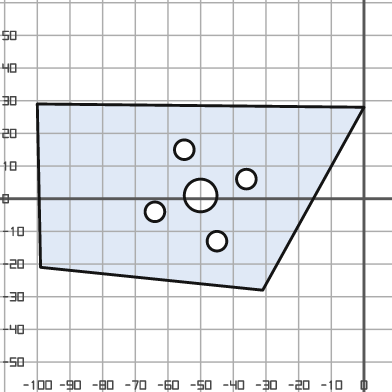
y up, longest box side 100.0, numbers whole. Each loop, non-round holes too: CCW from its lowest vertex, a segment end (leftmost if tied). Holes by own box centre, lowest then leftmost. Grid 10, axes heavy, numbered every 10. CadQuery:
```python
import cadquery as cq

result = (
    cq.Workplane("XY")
    .moveTo(-31.0, -28.0)
    .lineTo(0.0, 28.0)
    .lineTo(-100.0, 29.0)
    .lineTo(-99.0, -21.0)
    .close()
    .moveTo(-45.0, -13.0)
    .circle(3.0)
    .moveTo(-64.0, -4.0)
    .circle(3.0)
    .moveTo(-50.0, 1.0)
    .circle(5.0)
    .moveTo(-36.0, 6.0)
    .circle(3.0)
    .moveTo(-55.0, 15.0)
    .circle(3.0)
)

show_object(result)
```